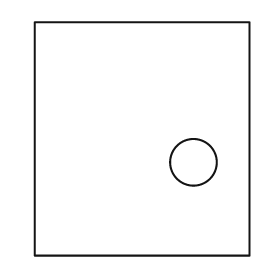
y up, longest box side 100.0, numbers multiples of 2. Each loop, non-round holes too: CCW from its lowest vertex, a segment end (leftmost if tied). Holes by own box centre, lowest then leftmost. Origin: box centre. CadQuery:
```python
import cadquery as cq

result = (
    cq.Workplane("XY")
    .moveTo(-46.0, -50.0)
    .lineTo(46.0, -50.0)
    .lineTo(46.0, 50.0)
    .lineTo(-46.0, 50.0)
    .close()
    .moveTo(22.0, -10.0)
    .circle(10.0)
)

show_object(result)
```